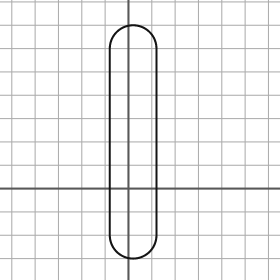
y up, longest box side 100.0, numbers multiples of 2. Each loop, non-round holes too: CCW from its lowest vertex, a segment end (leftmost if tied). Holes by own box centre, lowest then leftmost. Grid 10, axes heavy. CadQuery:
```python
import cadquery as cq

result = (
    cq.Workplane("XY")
    .moveTo(-8.0, -20.0)
    .threePointArc((2.0, -30.0), (12.0, -20.0))
    .lineTo(12.0, 60.0)
    .threePointArc((2.0, 70.0), (-8.0, 60.0))
    .close()
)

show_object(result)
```